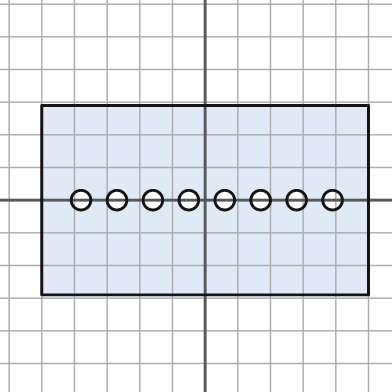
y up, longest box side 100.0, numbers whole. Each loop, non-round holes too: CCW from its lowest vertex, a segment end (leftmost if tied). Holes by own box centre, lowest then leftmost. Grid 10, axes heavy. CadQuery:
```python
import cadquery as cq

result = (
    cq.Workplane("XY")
    .moveTo(-50.0, -29.0)
    .lineTo(50.0, -29.0)
    .lineTo(50.0, 29.0)
    .lineTo(-50.0, 29.0)
    .close()
    .moveTo(-38.0, 0.0)
    .circle(3.0)
    .moveTo(-27.0, 0.0)
    .circle(3.0)
    .moveTo(-16.0, 0.0)
    .circle(3.0)
    .moveTo(-5.0, 0.0)
    .circle(3.0)
    .moveTo(6.0, 0.0)
    .circle(3.0)
    .moveTo(17.0, 0.0)
    .circle(3.0)
    .moveTo(28.0, 0.0)
    .circle(3.0)
    .moveTo(39.0, 0.0)
    .circle(3.0)
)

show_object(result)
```